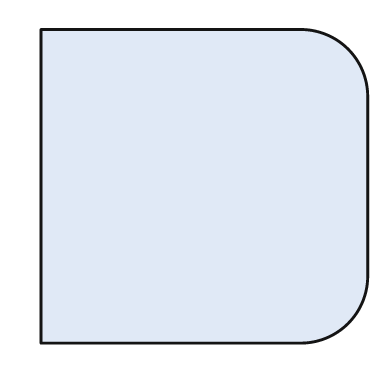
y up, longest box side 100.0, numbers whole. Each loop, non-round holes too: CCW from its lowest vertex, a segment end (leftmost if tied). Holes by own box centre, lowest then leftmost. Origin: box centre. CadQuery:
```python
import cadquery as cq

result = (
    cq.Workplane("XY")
    .moveTo(-50.0, -48.0)
    .lineTo(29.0, -48.0)
    .threePointArc((44.0, -42.0), (50.0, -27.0))
    .lineTo(50.0, 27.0)
    .threePointArc((44.0, 42.0), (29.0, 48.0))
    .lineTo(-50.0, 48.0)
    .close()
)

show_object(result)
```